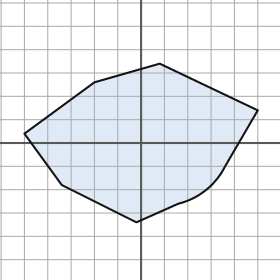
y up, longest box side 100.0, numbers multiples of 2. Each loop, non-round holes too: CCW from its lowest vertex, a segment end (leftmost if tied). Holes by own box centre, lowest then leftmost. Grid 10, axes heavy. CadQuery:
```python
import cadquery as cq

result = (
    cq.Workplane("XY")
    .moveTo(-2.0, -34.0)
    .lineTo(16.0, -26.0)
    .threePointArc((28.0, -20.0), (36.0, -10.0))
    .lineTo(50.0, 14.0)
    .lineTo(8.0, 34.0)
    .lineTo(-20.0, 26.0)
    .lineTo(-50.0, 4.0)
    .lineTo(-34.0, -18.0)
    .close()
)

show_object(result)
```